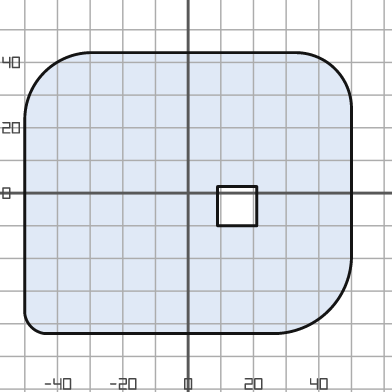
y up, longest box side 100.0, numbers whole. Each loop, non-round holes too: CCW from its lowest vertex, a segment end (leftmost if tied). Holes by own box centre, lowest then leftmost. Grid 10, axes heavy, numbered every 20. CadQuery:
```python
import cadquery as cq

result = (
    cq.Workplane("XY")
    .moveTo(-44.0, -43.0)
    .lineTo(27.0, -43.0)
    .threePointArc((43.0, -36.0), (50.0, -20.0))
    .lineTo(50.0, 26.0)
    .threePointArc((45.0, 38.0), (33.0, 43.0))
    .lineTo(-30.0, 43.0)
    .threePointArc((-44.0, 37.0), (-50.0, 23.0))
    .lineTo(-50.0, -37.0)
    .threePointArc((-48.0, -41.0), (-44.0, -43.0))
    .close()
    .moveTo(9.0, -10.0)
    .lineTo(21.0, -10.0)
    .lineTo(21.0, 2.0)
    .lineTo(9.0, 2.0)
    .close()
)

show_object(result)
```